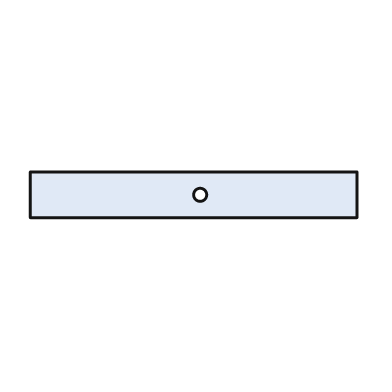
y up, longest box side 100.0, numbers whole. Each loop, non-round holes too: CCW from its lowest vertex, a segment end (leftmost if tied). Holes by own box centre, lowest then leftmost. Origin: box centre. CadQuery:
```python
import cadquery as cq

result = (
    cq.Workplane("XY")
    .moveTo(-50.0, -7.0)
    .lineTo(50.0, -7.0)
    .lineTo(50.0, 7.0)
    .lineTo(-50.0, 7.0)
    .close()
    .moveTo(2.0, 0.0)
    .circle(2.0)
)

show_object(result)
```